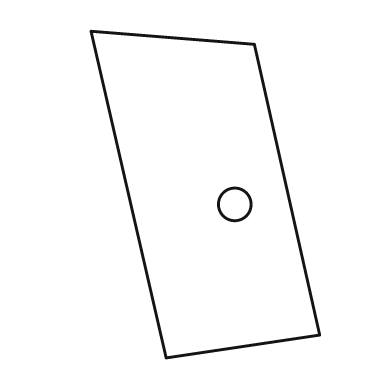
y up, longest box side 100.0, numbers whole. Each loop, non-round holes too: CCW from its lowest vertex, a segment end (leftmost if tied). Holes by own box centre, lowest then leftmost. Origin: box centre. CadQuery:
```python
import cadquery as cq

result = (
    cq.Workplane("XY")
    .moveTo(-12.0, -50.0)
    .lineTo(35.0, -43.0)
    .lineTo(15.0, 46.0)
    .lineTo(-35.0, 50.0)
    .close()
    .moveTo(9.0, -3.0)
    .circle(5.0)
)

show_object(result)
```